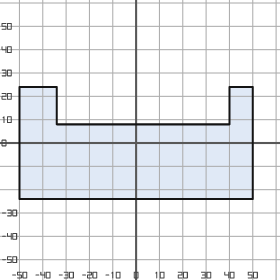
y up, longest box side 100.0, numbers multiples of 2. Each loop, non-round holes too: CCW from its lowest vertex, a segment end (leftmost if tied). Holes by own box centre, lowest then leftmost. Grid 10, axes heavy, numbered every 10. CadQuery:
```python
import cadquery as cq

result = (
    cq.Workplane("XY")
    .moveTo(-50.0, -24.0)
    .lineTo(50.0, -24.0)
    .lineTo(50.0, 24.0)
    .lineTo(40.0, 24.0)
    .lineTo(40.0, 8.0)
    .lineTo(-34.0, 8.0)
    .lineTo(-34.0, 24.0)
    .lineTo(-50.0, 24.0)
    .close()
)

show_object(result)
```